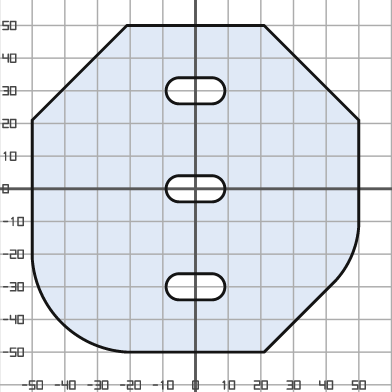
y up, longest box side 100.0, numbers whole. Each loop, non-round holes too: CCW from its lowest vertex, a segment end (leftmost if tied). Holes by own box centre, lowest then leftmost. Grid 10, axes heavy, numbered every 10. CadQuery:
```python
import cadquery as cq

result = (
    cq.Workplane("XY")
    .moveTo(-21.0, -50.0)
    .lineTo(21.0, -50.0)
    .lineTo(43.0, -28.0)
    .threePointArc((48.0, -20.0), (50.0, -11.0))
    .lineTo(50.0, 21.0)
    .lineTo(21.0, 50.0)
    .lineTo(-21.0, 50.0)
    .lineTo(-50.0, 21.0)
    .lineTo(-50.0, -21.0)
    .threePointArc((-41.0, -41.0), (-21.0, -50.0))
    .close()
    .moveTo(-5.0, -34.0)
    .lineTo(5.0, -34.0)
    .threePointArc((9.0, -30.0), (5.0, -26.0))
    .lineTo(-5.0, -26.0)
    .threePointArc((-9.0, -30.0), (-5.0, -34.0))
    .close()
    .moveTo(-5.0, -4.0)
    .lineTo(5.0, -4.0)
    .threePointArc((9.0, 0.0), (5.0, 4.0))
    .lineTo(-5.0, 4.0)
    .threePointArc((-9.0, 0.0), (-5.0, -4.0))
    .close()
    .moveTo(-5.0, 26.0)
    .lineTo(5.0, 26.0)
    .threePointArc((9.0, 30.0), (5.0, 34.0))
    .lineTo(-5.0, 34.0)
    .threePointArc((-9.0, 30.0), (-5.0, 26.0))
    .close()
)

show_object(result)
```